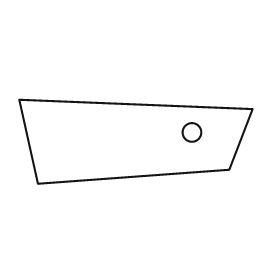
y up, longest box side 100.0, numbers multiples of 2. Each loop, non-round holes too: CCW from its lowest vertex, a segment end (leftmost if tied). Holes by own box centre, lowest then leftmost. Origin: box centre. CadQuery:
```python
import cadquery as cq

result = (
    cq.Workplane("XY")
    .moveTo(-42.0, -18.0)
    .lineTo(40.0, -12.0)
    .lineTo(50.0, 14.0)
    .lineTo(-50.0, 18.0)
    .close()
    .moveTo(24.0, 4.0)
    .circle(4.0)
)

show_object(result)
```